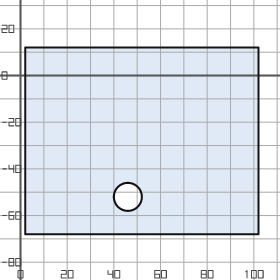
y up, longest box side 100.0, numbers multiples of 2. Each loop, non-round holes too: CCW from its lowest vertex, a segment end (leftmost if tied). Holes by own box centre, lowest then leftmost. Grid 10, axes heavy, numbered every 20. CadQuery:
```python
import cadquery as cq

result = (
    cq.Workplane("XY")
    .moveTo(2.0, -68.0)
    .lineTo(102.0, -68.0)
    .lineTo(102.0, 12.0)
    .lineTo(2.0, 12.0)
    .close()
    .moveTo(46.0, -52.0)
    .circle(6.0)
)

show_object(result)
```